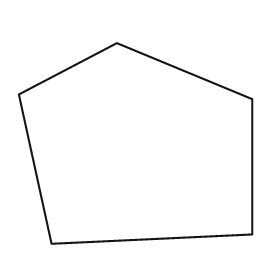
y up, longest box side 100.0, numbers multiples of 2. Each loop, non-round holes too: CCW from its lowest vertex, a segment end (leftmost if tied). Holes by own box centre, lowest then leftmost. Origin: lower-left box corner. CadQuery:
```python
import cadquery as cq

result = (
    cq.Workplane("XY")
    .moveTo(14.0, 0.0)
    .lineTo(100.0, 4.0)
    .lineTo(100.0, 62.0)
    .lineTo(42.0, 86.0)
    .lineTo(0.0, 64.0)
    .close()
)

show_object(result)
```